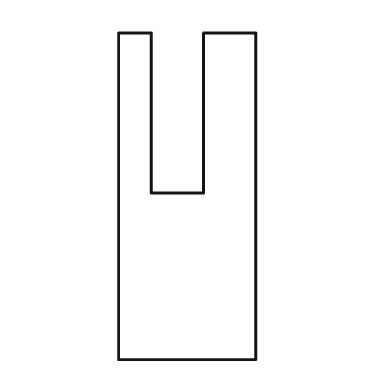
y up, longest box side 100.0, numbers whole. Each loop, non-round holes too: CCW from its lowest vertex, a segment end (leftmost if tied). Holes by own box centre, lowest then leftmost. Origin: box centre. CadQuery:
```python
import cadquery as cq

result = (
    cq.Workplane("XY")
    .moveTo(-21.0, -50.0)
    .lineTo(21.0, -50.0)
    .lineTo(21.0, 50.0)
    .lineTo(5.0, 50.0)
    .lineTo(5.0, 1.0)
    .lineTo(-11.0, 1.0)
    .lineTo(-11.0, 50.0)
    .lineTo(-21.0, 50.0)
    .close()
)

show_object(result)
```